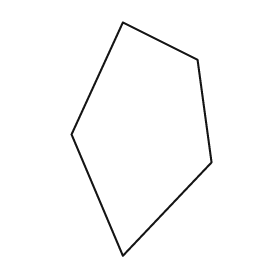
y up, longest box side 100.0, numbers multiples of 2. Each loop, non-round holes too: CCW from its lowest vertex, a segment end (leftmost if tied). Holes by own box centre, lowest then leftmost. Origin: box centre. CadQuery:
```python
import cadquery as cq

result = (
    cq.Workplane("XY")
    .moveTo(-8.0, -50.0)
    .lineTo(30.0, -10.0)
    .lineTo(24.0, 34.0)
    .lineTo(-8.0, 50.0)
    .lineTo(-30.0, 2.0)
    .close()
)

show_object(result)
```